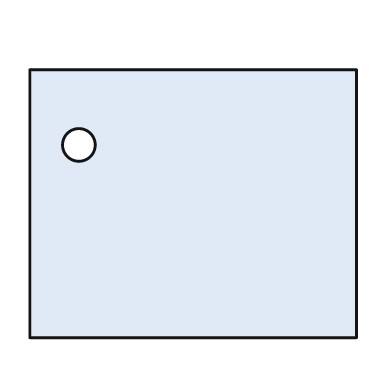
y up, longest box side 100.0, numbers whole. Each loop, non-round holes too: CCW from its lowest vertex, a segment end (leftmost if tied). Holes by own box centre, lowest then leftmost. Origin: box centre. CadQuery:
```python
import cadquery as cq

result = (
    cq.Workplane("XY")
    .moveTo(-50.0, -41.0)
    .lineTo(50.0, -41.0)
    .lineTo(50.0, 41.0)
    .lineTo(-50.0, 41.0)
    .close()
    .moveTo(-35.0, 18.0)
    .circle(5.0)
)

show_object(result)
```